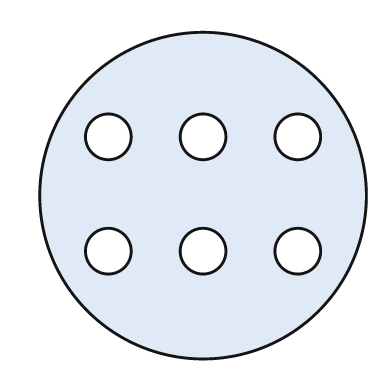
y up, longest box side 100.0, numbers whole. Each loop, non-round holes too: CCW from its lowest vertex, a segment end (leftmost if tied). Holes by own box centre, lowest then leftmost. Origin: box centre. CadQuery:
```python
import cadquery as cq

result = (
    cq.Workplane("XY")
    .moveTo(0.0, 0.0)
    .circle(50.0)
    .moveTo(-29.0, -17.0)
    .circle(7.0)
    .moveTo(0.0, -17.0)
    .circle(7.0)
    .moveTo(29.0, -17.0)
    .circle(7.0)
    .moveTo(-29.0, 18.0)
    .circle(7.0)
    .moveTo(0.0, 18.0)
    .circle(7.0)
    .moveTo(29.0, 18.0)
    .circle(7.0)
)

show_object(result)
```